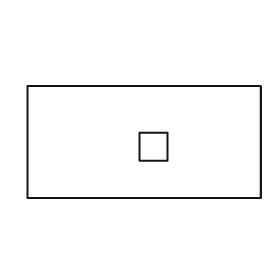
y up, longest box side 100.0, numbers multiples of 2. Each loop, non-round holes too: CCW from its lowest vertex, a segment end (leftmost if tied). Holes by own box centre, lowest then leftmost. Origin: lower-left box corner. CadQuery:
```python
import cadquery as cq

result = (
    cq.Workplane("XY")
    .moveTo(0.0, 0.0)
    .lineTo(100.0, 0.0)
    .lineTo(100.0, 48.0)
    .lineTo(0.0, 48.0)
    .close()
    .moveTo(48.0, 16.0)
    .lineTo(60.0, 16.0)
    .lineTo(60.0, 28.0)
    .lineTo(48.0, 28.0)
    .close()
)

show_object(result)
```